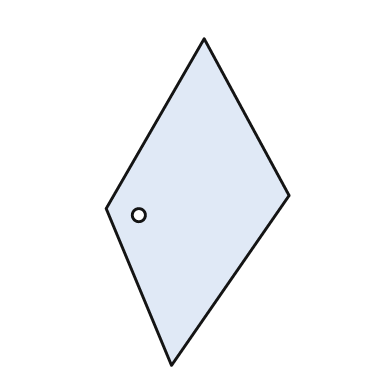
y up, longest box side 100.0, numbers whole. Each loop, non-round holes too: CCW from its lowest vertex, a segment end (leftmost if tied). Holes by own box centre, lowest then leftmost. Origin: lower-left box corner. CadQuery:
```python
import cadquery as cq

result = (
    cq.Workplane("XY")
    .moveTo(20.0, 0.0)
    .lineTo(56.0, 52.0)
    .lineTo(30.0, 100.0)
    .lineTo(0.0, 48.0)
    .close()
    .moveTo(10.0, 46.0)
    .circle(2.0)
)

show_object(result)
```